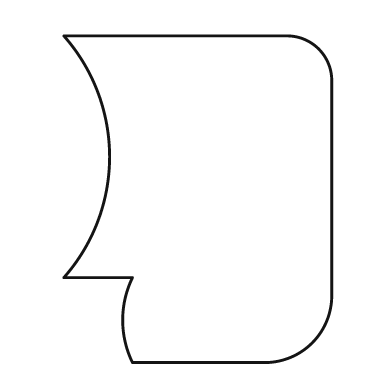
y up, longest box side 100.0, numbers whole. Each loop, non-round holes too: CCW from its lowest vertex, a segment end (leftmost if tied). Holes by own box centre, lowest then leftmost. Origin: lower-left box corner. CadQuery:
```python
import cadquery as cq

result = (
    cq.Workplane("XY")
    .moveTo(21.0, 0.0)
    .lineTo(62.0, 0.0)
    .threePointArc((76.0, 6.0), (82.0, 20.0))
    .lineTo(82.0, 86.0)
    .threePointArc((78.0, 96.0), (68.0, 100.0))
    .lineTo(0.0, 100.0)
    .threePointArc((14.0, 63.0), (0.0, 26.0))
    .lineTo(21.0, 26.0)
    .threePointArc((18.0, 13.0), (21.0, 0.0))
    .close()
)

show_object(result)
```